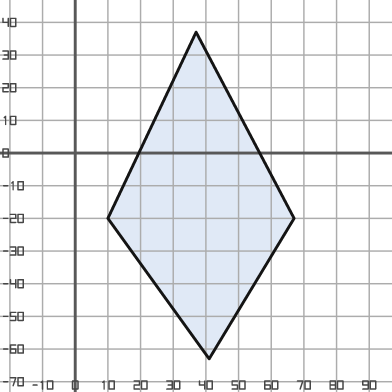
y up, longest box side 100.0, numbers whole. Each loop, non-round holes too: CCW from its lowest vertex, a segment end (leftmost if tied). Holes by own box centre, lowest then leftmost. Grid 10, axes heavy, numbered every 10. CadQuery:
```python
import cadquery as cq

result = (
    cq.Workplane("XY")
    .moveTo(41.0, -63.0)
    .lineTo(67.0, -20.0)
    .lineTo(37.0, 37.0)
    .lineTo(10.0, -20.0)
    .close()
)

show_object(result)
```